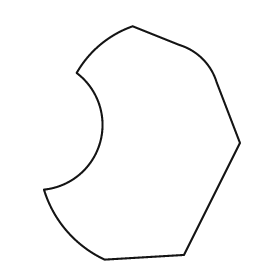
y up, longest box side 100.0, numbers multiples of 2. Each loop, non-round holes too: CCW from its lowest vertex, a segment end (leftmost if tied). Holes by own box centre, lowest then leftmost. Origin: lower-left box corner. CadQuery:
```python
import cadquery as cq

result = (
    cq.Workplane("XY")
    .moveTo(26.0, 0.0)
    .lineTo(60.0, 2.0)
    .lineTo(84.0, 50.0)
    .lineTo(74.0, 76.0)
    .threePointArc((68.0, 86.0), (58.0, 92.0))
    .lineTo(38.0, 100.0)
    .threePointArc((24.0, 92.0), (14.0, 80.0))
    .threePointArc((24.0, 50.0), (0.0, 30.0))
    .threePointArc((10.0, 12.0), (26.0, 0.0))
    .close()
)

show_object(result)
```